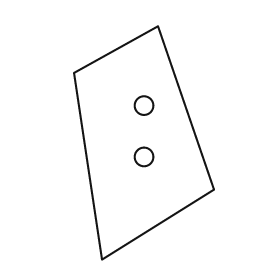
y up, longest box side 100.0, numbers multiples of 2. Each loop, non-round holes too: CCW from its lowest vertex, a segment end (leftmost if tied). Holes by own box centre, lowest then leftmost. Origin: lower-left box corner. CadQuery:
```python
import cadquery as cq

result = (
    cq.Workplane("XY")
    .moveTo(12.0, 0.0)
    .lineTo(60.0, 30.0)
    .lineTo(36.0, 100.0)
    .lineTo(0.0, 80.0)
    .close()
    .moveTo(30.0, 44.0)
    .circle(4.0)
    .moveTo(30.0, 66.0)
    .circle(4.0)
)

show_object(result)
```